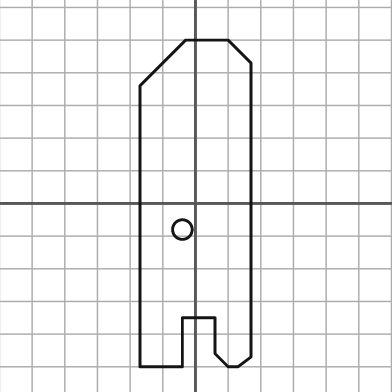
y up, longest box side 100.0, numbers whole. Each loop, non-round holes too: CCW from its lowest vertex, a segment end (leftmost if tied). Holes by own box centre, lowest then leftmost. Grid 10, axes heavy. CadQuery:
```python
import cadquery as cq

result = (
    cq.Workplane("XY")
    .moveTo(-17.0, -50.0)
    .lineTo(-4.0, -50.0)
    .lineTo(-4.0, -35.0)
    .lineTo(6.0, -35.0)
    .lineTo(6.0, -46.0)
    .lineTo(10.0, -50.0)
    .lineTo(13.0, -50.0)
    .lineTo(17.0, -47.0)
    .lineTo(17.0, 43.0)
    .lineTo(10.0, 50.0)
    .lineTo(-3.0, 50.0)
    .lineTo(-17.0, 36.0)
    .close()
    .moveTo(-4.0, -8.0)
    .circle(3.0)
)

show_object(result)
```